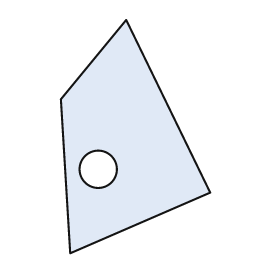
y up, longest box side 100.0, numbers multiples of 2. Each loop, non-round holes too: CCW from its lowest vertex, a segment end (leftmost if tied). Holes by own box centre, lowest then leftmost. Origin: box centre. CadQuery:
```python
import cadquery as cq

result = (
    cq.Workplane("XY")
    .moveTo(-28.0, -50.0)
    .lineTo(32.0, -24.0)
    .lineTo(-4.0, 50.0)
    .lineTo(-32.0, 16.0)
    .close()
    .moveTo(-16.0, -14.0)
    .circle(8.0)
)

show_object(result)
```